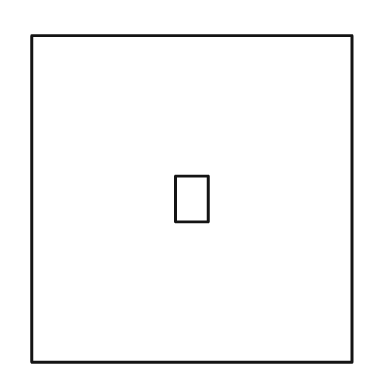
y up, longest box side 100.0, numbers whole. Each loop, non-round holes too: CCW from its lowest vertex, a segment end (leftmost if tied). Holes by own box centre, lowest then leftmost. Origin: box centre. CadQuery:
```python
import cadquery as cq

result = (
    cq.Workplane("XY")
    .moveTo(-49.0, -50.0)
    .lineTo(49.0, -50.0)
    .lineTo(49.0, 50.0)
    .lineTo(-49.0, 50.0)
    .close()
    .moveTo(-5.0, -7.0)
    .lineTo(5.0, -7.0)
    .lineTo(5.0, 7.0)
    .lineTo(-5.0, 7.0)
    .close()
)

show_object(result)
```